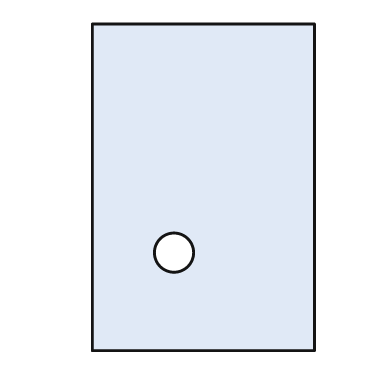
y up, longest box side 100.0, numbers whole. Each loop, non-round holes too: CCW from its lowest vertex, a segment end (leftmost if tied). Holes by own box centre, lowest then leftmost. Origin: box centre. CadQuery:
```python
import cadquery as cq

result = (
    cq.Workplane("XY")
    .moveTo(-34.0, -50.0)
    .lineTo(34.0, -50.0)
    .lineTo(34.0, 50.0)
    .lineTo(-34.0, 50.0)
    .close()
    .moveTo(-9.0, -20.0)
    .circle(6.0)
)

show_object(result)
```